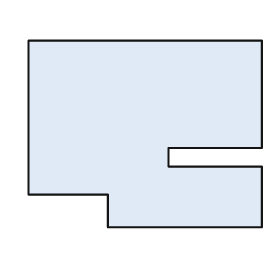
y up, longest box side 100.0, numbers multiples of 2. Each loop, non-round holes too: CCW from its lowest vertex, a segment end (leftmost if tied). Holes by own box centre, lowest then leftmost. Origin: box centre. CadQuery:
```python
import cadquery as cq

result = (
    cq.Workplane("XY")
    .moveTo(-16.0, -40.0)
    .lineTo(50.0, -40.0)
    .lineTo(50.0, -14.0)
    .lineTo(10.0, -14.0)
    .lineTo(10.0, -6.0)
    .lineTo(50.0, -6.0)
    .lineTo(50.0, 40.0)
    .lineTo(-50.0, 40.0)
    .lineTo(-50.0, -26.0)
    .lineTo(-16.0, -26.0)
    .close()
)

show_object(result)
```